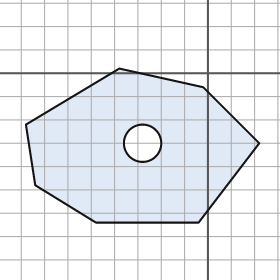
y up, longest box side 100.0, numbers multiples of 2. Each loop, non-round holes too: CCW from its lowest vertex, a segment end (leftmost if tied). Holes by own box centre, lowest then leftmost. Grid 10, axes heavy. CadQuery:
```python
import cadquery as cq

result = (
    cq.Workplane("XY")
    .moveTo(-48.0, -64.0)
    .lineTo(-4.0, -64.0)
    .lineTo(22.0, -30.0)
    .lineTo(-2.0, -6.0)
    .lineTo(-38.0, 2.0)
    .lineTo(-78.0, -22.0)
    .lineTo(-74.0, -48.0)
    .close()
    .moveTo(-28.0, -30.0)
    .circle(8.0)
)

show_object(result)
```